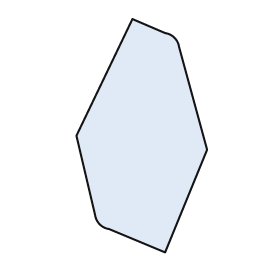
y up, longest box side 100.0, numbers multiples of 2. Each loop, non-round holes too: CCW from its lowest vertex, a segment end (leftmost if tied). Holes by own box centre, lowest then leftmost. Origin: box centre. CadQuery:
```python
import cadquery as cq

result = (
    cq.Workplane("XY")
    .moveTo(10.0, -50.0)
    .lineTo(28.0, -6.0)
    .lineTo(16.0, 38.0)
    .threePointArc((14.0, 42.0), (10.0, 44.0))
    .lineTo(-4.0, 50.0)
    .lineTo(-28.0, 0.0)
    .lineTo(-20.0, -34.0)
    .threePointArc((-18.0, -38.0), (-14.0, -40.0))
    .close()
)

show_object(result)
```